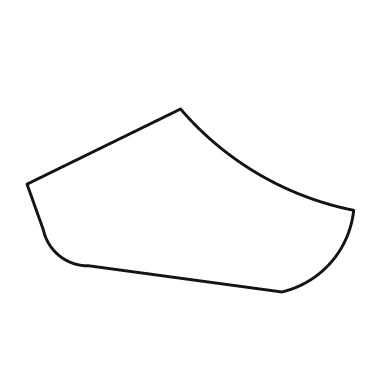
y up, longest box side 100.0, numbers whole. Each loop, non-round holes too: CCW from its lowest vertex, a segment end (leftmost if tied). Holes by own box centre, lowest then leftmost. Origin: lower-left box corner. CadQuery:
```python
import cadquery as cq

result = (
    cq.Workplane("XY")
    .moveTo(78.0, 0.0)
    .threePointArc((93.0, 9.0), (100.0, 25.0))
    .threePointArc((71.0, 36.0), (47.0, 56.0))
    .lineTo(0.0, 33.0)
    .lineTo(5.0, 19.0)
    .threePointArc((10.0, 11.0), (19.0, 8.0))
    .close()
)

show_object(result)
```